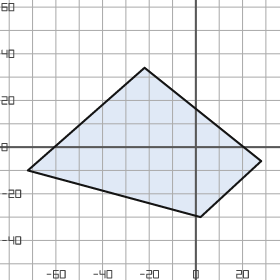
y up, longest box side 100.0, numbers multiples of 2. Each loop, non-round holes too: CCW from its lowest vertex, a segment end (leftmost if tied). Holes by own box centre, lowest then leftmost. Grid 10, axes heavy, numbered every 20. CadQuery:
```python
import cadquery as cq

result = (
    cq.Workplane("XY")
    .moveTo(2.0, -30.0)
    .lineTo(28.0, -6.0)
    .lineTo(-22.0, 34.0)
    .lineTo(-72.0, -10.0)
    .close()
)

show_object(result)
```